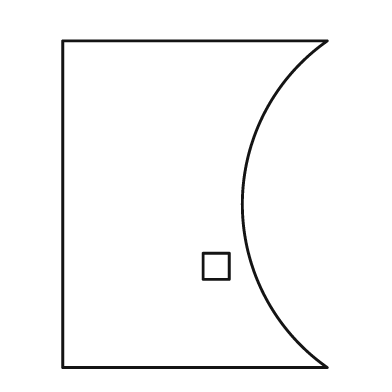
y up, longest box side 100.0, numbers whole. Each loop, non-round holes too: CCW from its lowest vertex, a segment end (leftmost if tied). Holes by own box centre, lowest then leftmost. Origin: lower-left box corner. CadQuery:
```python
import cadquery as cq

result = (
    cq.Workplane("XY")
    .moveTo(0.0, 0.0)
    .lineTo(81.0, 0.0)
    .threePointArc((55.0, 50.0), (81.0, 100.0))
    .lineTo(0.0, 100.0)
    .close()
    .moveTo(43.0, 27.0)
    .lineTo(51.0, 27.0)
    .lineTo(51.0, 35.0)
    .lineTo(43.0, 35.0)
    .close()
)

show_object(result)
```